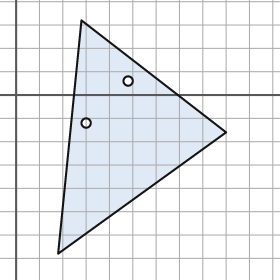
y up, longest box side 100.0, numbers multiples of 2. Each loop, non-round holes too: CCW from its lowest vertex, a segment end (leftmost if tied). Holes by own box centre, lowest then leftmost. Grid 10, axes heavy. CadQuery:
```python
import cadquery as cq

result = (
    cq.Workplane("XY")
    .moveTo(18.0, -68.0)
    .lineTo(90.0, -16.0)
    .lineTo(28.0, 32.0)
    .close()
    .moveTo(30.0, -12.0)
    .circle(2.0)
    .moveTo(48.0, 6.0)
    .circle(2.0)
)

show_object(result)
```